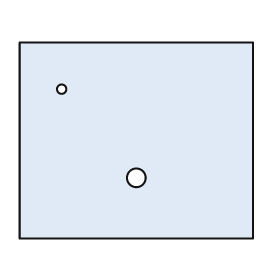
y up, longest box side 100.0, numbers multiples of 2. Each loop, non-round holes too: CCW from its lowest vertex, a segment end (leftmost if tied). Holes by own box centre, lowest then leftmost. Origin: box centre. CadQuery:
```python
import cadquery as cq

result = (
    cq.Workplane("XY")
    .moveTo(-50.0, -42.0)
    .lineTo(50.0, -42.0)
    .lineTo(50.0, 42.0)
    .lineTo(-50.0, 42.0)
    .close()
    .moveTo(0.0, -16.0)
    .circle(4.0)
    .moveTo(-32.0, 22.0)
    .circle(2.0)
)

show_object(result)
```